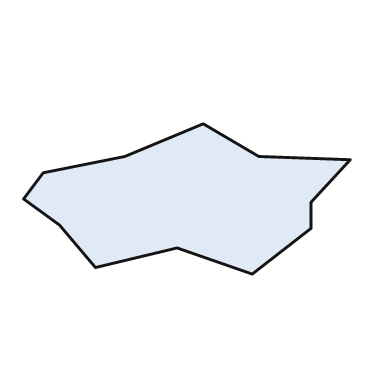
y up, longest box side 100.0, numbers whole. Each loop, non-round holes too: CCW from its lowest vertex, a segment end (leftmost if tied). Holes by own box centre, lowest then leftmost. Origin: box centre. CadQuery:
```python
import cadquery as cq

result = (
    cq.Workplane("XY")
    .moveTo(20.0, -23.0)
    .lineTo(38.0, -9.0)
    .lineTo(38.0, -1.0)
    .lineTo(50.0, 12.0)
    .lineTo(22.0, 13.0)
    .lineTo(5.0, 23.0)
    .lineTo(-19.0, 13.0)
    .lineTo(-44.0, 8.0)
    .lineTo(-50.0, 0.0)
    .lineTo(-39.0, -8.0)
    .lineTo(-28.0, -21.0)
    .lineTo(-3.0, -15.0)
    .close()
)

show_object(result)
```